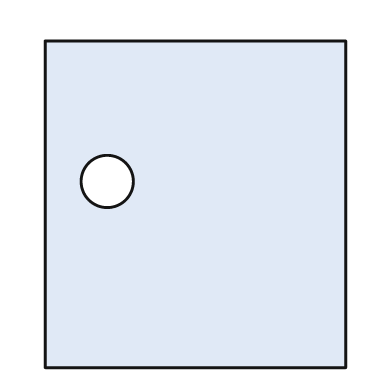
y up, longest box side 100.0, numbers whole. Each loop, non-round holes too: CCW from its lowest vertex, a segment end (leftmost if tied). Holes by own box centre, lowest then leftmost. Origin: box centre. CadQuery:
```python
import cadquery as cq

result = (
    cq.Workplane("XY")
    .moveTo(-46.0, -50.0)
    .lineTo(46.0, -50.0)
    .lineTo(46.0, 50.0)
    .lineTo(-46.0, 50.0)
    .close()
    .moveTo(-27.0, 7.0)
    .circle(8.0)
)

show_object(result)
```